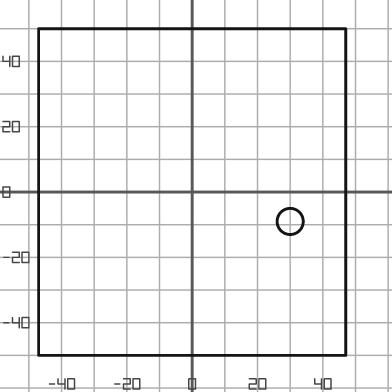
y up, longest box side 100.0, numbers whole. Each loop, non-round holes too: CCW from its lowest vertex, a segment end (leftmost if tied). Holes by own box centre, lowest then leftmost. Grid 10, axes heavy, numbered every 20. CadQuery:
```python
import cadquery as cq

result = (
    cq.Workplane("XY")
    .moveTo(-47.0, -50.0)
    .lineTo(47.0, -50.0)
    .lineTo(47.0, 50.0)
    .lineTo(-47.0, 50.0)
    .close()
    .moveTo(30.0, -9.0)
    .circle(4.0)
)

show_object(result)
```